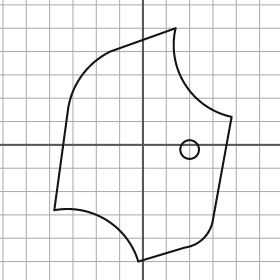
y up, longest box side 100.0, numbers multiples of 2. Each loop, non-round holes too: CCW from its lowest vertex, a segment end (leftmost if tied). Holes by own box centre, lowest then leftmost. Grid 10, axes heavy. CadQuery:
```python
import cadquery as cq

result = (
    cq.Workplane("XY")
    .moveTo(-2.0, -50.0)
    .lineTo(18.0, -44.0)
    .threePointArc((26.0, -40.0), (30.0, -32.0))
    .lineTo(38.0, 12.0)
    .threePointArc((18.0, 26.0), (14.0, 50.0))
    .lineTo(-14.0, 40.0)
    .threePointArc((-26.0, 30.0), (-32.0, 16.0))
    .lineTo(-38.0, -28.0)
    .threePointArc((-16.0, -32.0), (-2.0, -50.0))
    .close()
    .moveTo(20.0, -2.0)
    .circle(4.0)
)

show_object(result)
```